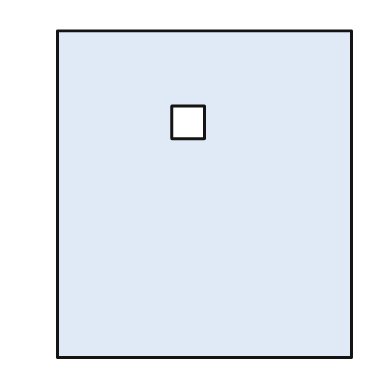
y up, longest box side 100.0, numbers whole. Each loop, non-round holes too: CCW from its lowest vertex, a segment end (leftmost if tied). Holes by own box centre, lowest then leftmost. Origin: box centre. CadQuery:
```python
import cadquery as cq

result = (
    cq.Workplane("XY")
    .moveTo(-45.0, -50.0)
    .lineTo(45.0, -50.0)
    .lineTo(45.0, 50.0)
    .lineTo(-45.0, 50.0)
    .close()
    .moveTo(-10.0, 17.0)
    .lineTo(0.0, 17.0)
    .lineTo(0.0, 27.0)
    .lineTo(-10.0, 27.0)
    .close()
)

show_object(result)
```